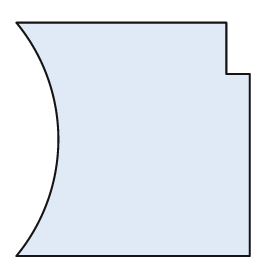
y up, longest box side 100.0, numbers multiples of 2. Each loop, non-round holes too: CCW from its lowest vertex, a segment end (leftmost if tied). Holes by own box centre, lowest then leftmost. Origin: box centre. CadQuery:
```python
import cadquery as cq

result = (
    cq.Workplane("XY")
    .moveTo(-50.0, -50.0)
    .lineTo(50.0, -50.0)
    .lineTo(50.0, 28.0)
    .lineTo(40.0, 28.0)
    .lineTo(40.0, 50.0)
    .lineTo(-50.0, 50.0)
    .threePointArc((-32.0, 0.0), (-50.0, -50.0))
    .close()
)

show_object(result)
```